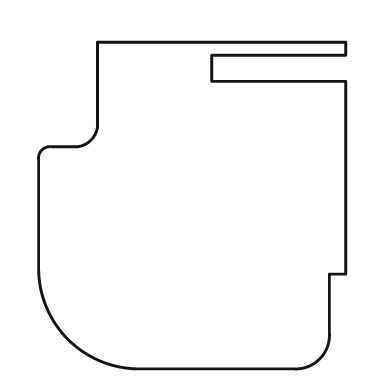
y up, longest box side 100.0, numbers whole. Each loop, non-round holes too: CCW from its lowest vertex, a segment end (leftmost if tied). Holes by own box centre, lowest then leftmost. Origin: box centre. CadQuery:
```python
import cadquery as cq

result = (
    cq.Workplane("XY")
    .moveTo(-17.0, -50.0)
    .lineTo(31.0, -50.0)
    .threePointArc((39.0, -47.0), (42.0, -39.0))
    .lineTo(42.0, -21.0)
    .lineTo(47.0, -21.0)
    .lineTo(47.0, 38.0)
    .lineTo(6.0, 38.0)
    .lineTo(6.0, 46.0)
    .lineTo(47.0, 46.0)
    .lineTo(47.0, 50.0)
    .lineTo(-29.0, 50.0)
    .lineTo(-29.0, 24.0)
    .threePointArc((-31.0, 20.0), (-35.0, 18.0))
    .lineTo(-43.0, 18.0)
    .threePointArc((-46.0, 17.0), (-47.0, 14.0))
    .lineTo(-47.0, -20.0)
    .threePointArc((-38.0, -41.0), (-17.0, -50.0))
    .close()
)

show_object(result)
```